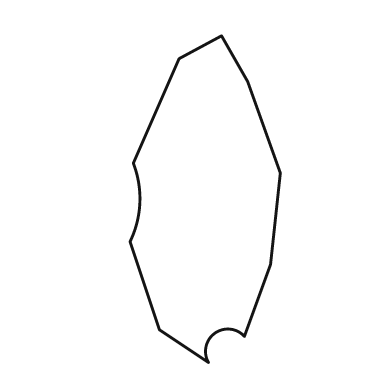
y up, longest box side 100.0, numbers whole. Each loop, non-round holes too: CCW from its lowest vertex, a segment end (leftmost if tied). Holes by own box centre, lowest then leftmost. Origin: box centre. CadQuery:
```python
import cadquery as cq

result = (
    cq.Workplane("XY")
    .moveTo(1.0, -50.0)
    .threePointArc((3.0, -41.0), (12.0, -42.0))
    .lineTo(20.0, -20.0)
    .lineTo(23.0, 8.0)
    .lineTo(13.0, 36.0)
    .lineTo(5.0, 50.0)
    .lineTo(-8.0, 43.0)
    .lineTo(-22.0, 11.0)
    .threePointArc((-20.0, -1.0), (-23.0, -13.0))
    .lineTo(-14.0, -40.0)
    .close()
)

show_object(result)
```